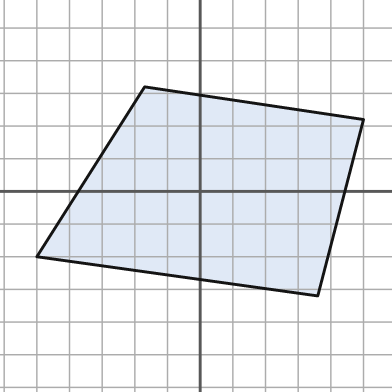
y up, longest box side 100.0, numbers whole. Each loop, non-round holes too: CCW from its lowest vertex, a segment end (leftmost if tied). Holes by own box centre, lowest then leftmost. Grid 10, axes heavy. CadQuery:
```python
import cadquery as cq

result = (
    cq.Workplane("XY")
    .moveTo(36.0, -32.0)
    .lineTo(50.0, 22.0)
    .lineTo(-17.0, 32.0)
    .lineTo(-50.0, -20.0)
    .close()
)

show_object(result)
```